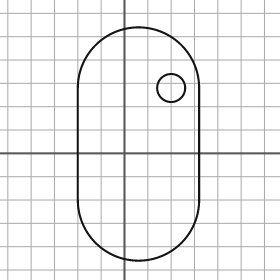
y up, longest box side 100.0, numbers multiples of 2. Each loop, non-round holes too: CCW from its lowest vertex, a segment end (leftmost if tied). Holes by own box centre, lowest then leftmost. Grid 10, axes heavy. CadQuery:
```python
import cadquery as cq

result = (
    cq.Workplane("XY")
    .moveTo(-20.0, -20.0)
    .threePointArc((6.0, -46.0), (32.0, -20.0))
    .lineTo(32.0, 28.0)
    .threePointArc((6.0, 54.0), (-20.0, 28.0))
    .close()
    .moveTo(20.0, 28.0)
    .circle(6.0)
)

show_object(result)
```